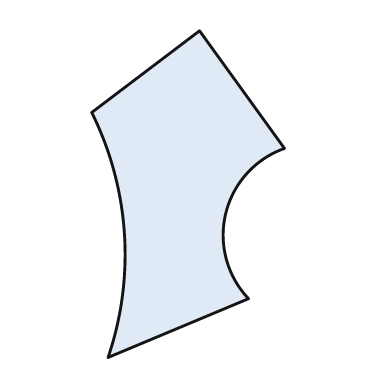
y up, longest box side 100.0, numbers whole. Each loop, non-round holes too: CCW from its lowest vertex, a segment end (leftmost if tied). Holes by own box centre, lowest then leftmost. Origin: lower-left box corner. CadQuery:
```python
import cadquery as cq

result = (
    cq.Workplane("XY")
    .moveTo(5.0, 0.0)
    .lineTo(48.0, 18.0)
    .threePointArc((41.0, 44.0), (59.0, 64.0))
    .lineTo(33.0, 100.0)
    .lineTo(0.0, 75.0)
    .threePointArc((10.0, 38.0), (5.0, 0.0))
    .close()
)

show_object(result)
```